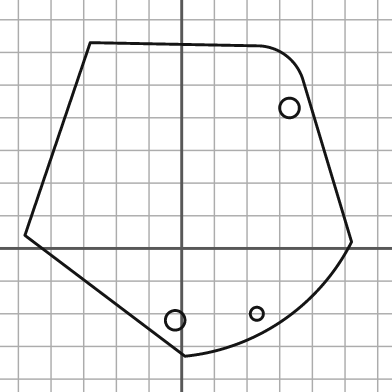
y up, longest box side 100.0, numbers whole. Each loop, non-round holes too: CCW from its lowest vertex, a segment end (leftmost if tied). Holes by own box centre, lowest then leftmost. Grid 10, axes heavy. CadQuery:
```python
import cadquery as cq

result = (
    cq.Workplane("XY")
    .moveTo(1.0, -33.0)
    .threePointArc((31.0, -22.0), (52.0, 2.0))
    .lineTo(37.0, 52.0)
    .threePointArc((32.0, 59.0), (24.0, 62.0))
    .lineTo(-28.0, 63.0)
    .lineTo(-48.0, 4.0)
    .close()
    .moveTo(-2.0, -22.0)
    .circle(3.0)
    .moveTo(23.0, -20.0)
    .circle(2.0)
    .moveTo(33.0, 43.0)
    .circle(3.0)
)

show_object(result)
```